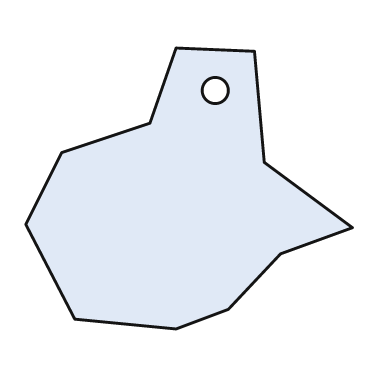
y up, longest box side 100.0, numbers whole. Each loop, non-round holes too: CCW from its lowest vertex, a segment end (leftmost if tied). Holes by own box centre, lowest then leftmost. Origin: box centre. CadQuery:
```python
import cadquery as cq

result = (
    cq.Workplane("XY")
    .moveTo(-4.0, -43.0)
    .lineTo(12.0, -37.0)
    .lineTo(28.0, -20.0)
    .lineTo(50.0, -12.0)
    .lineTo(23.0, 8.0)
    .lineTo(20.0, 42.0)
    .lineTo(-4.0, 43.0)
    .lineTo(-12.0, 20.0)
    .lineTo(-39.0, 11.0)
    .lineTo(-50.0, -11.0)
    .lineTo(-35.0, -40.0)
    .close()
    .moveTo(8.0, 30.0)
    .circle(4.0)
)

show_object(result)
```